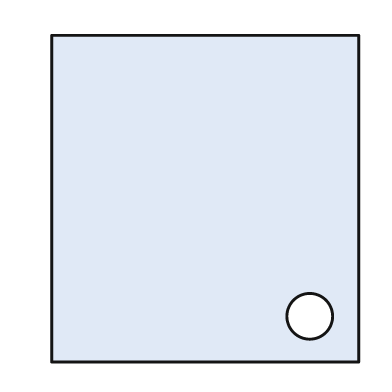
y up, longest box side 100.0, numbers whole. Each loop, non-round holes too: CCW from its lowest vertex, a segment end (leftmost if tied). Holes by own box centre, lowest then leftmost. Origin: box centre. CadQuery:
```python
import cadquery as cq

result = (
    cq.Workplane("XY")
    .moveTo(-47.0, -50.0)
    .lineTo(47.0, -50.0)
    .lineTo(47.0, 50.0)
    .lineTo(-47.0, 50.0)
    .close()
    .moveTo(32.0, -36.0)
    .circle(7.0)
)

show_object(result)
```